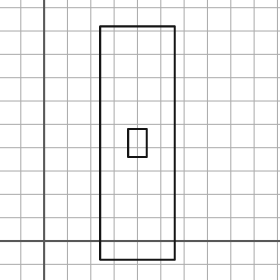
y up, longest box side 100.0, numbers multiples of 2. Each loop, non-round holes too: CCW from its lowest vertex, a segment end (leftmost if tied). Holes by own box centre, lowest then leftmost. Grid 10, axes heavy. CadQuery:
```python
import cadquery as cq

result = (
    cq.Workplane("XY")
    .moveTo(24.0, -8.0)
    .lineTo(56.0, -8.0)
    .lineTo(56.0, 92.0)
    .lineTo(24.0, 92.0)
    .close()
    .moveTo(36.0, 36.0)
    .lineTo(44.0, 36.0)
    .lineTo(44.0, 48.0)
    .lineTo(36.0, 48.0)
    .close()
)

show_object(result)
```